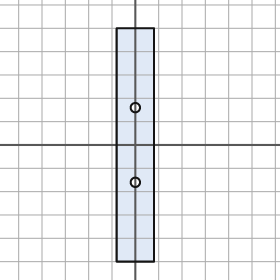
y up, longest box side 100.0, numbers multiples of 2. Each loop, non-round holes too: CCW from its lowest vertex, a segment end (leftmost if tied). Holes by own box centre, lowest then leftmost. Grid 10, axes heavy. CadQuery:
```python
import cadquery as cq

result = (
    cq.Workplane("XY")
    .moveTo(-8.0, -50.0)
    .lineTo(8.0, -50.0)
    .lineTo(8.0, 50.0)
    .lineTo(-8.0, 50.0)
    .close()
    .moveTo(0.0, -16.0)
    .circle(2.0)
    .moveTo(0.0, 16.0)
    .circle(2.0)
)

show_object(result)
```